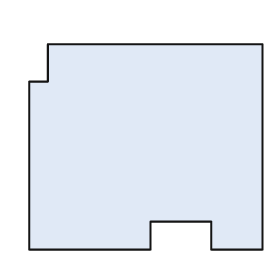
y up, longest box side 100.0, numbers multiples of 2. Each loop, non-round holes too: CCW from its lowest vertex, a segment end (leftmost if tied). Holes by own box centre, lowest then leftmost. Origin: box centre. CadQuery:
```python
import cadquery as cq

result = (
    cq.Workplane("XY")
    .moveTo(-50.0, -44.0)
    .lineTo(2.0, -44.0)
    .lineTo(2.0, -32.0)
    .lineTo(28.0, -32.0)
    .lineTo(28.0, -44.0)
    .lineTo(50.0, -44.0)
    .lineTo(50.0, 44.0)
    .lineTo(-42.0, 44.0)
    .lineTo(-42.0, 28.0)
    .lineTo(-50.0, 28.0)
    .close()
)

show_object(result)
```